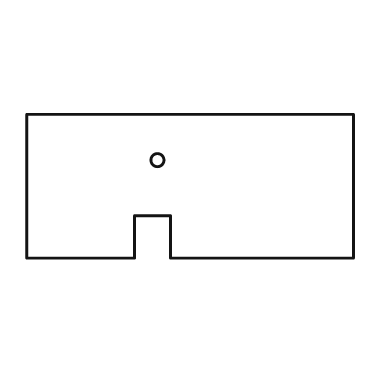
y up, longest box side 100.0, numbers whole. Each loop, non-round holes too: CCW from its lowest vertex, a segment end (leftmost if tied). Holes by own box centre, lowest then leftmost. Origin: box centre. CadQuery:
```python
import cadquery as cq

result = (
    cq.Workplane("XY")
    .moveTo(-50.0, -22.0)
    .lineTo(-17.0, -22.0)
    .lineTo(-17.0, -9.0)
    .lineTo(-6.0, -9.0)
    .lineTo(-6.0, -22.0)
    .lineTo(50.0, -22.0)
    .lineTo(50.0, 22.0)
    .lineTo(-50.0, 22.0)
    .close()
    .moveTo(-10.0, 8.0)
    .circle(2.0)
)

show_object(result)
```